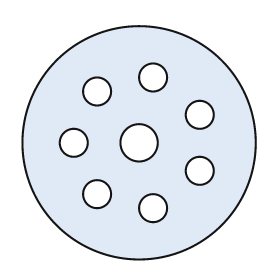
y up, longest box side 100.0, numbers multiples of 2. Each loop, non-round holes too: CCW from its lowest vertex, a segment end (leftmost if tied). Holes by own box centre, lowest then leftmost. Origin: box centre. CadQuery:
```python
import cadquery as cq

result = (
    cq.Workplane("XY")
    .moveTo(0.0, 0.0)
    .circle(50.0)
    .moveTo(6.0, -28.0)
    .circle(6.0)
    .moveTo(-18.0, -22.0)
    .circle(6.0)
    .moveTo(26.0, -12.0)
    .circle(6.0)
    .moveTo(-28.0, 0.0)
    .circle(6.0)
    .moveTo(0.0, 0.0)
    .circle(8.0)
    .moveTo(26.0, 12.0)
    .circle(6.0)
    .moveTo(-18.0, 22.0)
    .circle(6.0)
    .moveTo(6.0, 28.0)
    .circle(6.0)
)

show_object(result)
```